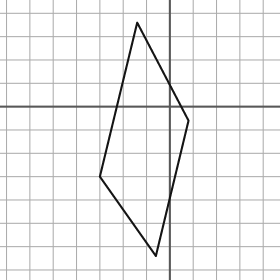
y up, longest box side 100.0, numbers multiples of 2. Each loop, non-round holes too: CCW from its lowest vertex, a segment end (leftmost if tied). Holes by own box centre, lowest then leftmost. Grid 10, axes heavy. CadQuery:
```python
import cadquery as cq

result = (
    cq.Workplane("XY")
    .moveTo(-6.0, -64.0)
    .lineTo(8.0, -6.0)
    .lineTo(-14.0, 36.0)
    .lineTo(-30.0, -30.0)
    .close()
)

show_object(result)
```